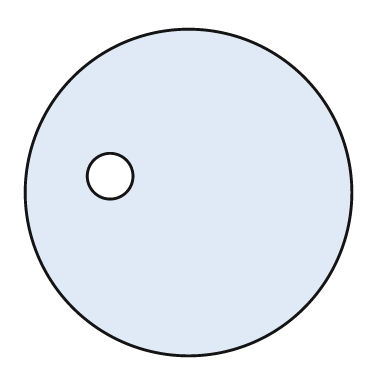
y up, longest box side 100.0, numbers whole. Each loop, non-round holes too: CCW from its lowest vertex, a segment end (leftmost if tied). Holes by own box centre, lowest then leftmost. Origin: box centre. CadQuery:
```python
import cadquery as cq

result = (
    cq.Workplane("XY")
    .moveTo(0.0, 0.0)
    .circle(50.0)
    .moveTo(-24.0, 5.0)
    .circle(7.0)
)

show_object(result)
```